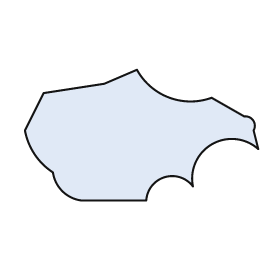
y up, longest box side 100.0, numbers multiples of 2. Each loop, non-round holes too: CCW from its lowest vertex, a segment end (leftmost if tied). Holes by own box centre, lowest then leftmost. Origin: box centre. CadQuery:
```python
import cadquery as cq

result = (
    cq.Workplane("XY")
    .moveTo(-26.0, -28.0)
    .lineTo(2.0, -28.0)
    .threePointArc((10.0, -18.0), (22.0, -22.0))
    .threePointArc((30.0, -4.0), (50.0, -6.0))
    .lineTo(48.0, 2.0)
    .threePointArc((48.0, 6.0), (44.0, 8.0))
    .lineTo(30.0, 16.0)
    .threePointArc((12.0, 16.0), (-2.0, 28.0))
    .lineTo(-16.0, 22.0)
    .lineTo(-42.0, 18.0)
    .lineTo(-50.0, 2.0)
    .threePointArc((-46.0, -8.0), (-38.0, -16.0))
    .threePointArc((-34.0, -24.0), (-26.0, -28.0))
    .close()
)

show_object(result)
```